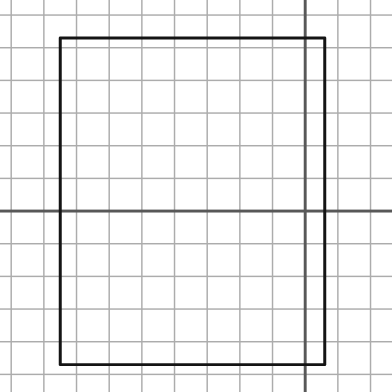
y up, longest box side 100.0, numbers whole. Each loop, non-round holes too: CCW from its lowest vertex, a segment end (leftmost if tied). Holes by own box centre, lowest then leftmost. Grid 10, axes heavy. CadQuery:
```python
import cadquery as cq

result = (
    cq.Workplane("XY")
    .moveTo(-75.0, -47.0)
    .lineTo(6.0, -47.0)
    .lineTo(6.0, 53.0)
    .lineTo(-75.0, 53.0)
    .close()
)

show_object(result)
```